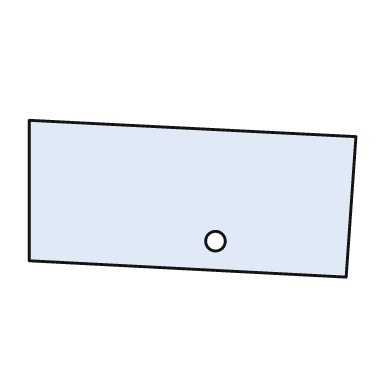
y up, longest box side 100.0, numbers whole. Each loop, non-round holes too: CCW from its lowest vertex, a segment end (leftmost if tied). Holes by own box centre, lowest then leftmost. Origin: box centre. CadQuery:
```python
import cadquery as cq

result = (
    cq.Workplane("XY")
    .moveTo(47.0, -24.0)
    .lineTo(50.0, 19.0)
    .lineTo(-50.0, 24.0)
    .lineTo(-50.0, -19.0)
    .close()
    .moveTo(7.0, -13.0)
    .circle(3.0)
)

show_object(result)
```